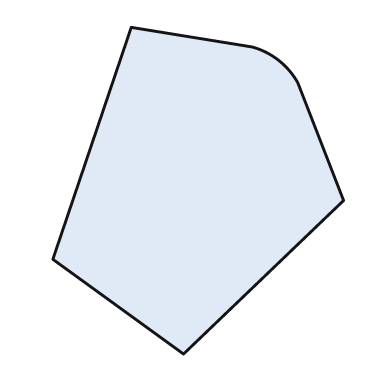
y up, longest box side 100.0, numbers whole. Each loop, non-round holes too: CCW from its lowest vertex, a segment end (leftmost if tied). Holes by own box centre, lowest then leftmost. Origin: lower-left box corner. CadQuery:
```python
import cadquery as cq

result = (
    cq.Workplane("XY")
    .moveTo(40.0, 0.0)
    .lineTo(89.0, 47.0)
    .lineTo(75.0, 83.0)
    .threePointArc((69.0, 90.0), (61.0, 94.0))
    .lineTo(24.0, 100.0)
    .lineTo(0.0, 29.0)
    .close()
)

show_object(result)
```